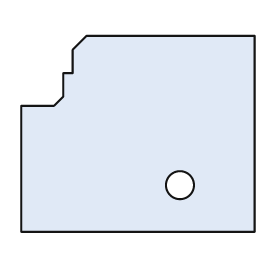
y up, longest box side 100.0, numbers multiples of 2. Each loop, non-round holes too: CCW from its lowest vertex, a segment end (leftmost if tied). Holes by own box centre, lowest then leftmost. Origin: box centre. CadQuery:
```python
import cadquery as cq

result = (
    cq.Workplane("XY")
    .moveTo(-50.0, -42.0)
    .lineTo(50.0, -42.0)
    .lineTo(50.0, 42.0)
    .lineTo(-22.0, 42.0)
    .lineTo(-28.0, 36.0)
    .lineTo(-28.0, 26.0)
    .lineTo(-32.0, 26.0)
    .lineTo(-32.0, 16.0)
    .lineTo(-36.0, 12.0)
    .lineTo(-50.0, 12.0)
    .close()
    .moveTo(18.0, -22.0)
    .circle(6.0)
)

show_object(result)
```